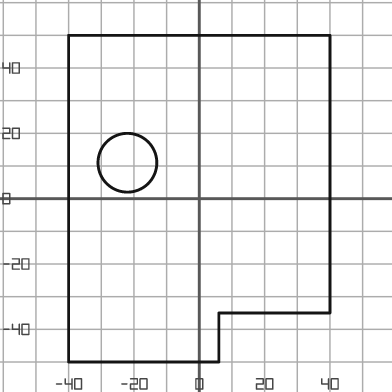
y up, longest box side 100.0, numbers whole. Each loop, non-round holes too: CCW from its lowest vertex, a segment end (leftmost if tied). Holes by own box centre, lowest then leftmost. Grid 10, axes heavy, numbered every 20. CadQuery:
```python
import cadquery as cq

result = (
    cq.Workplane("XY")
    .moveTo(-40.0, -50.0)
    .lineTo(6.0, -50.0)
    .lineTo(6.0, -35.0)
    .lineTo(40.0, -35.0)
    .lineTo(40.0, 50.0)
    .lineTo(-40.0, 50.0)
    .close()
    .moveTo(-22.0, 11.0)
    .circle(9.0)
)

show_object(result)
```